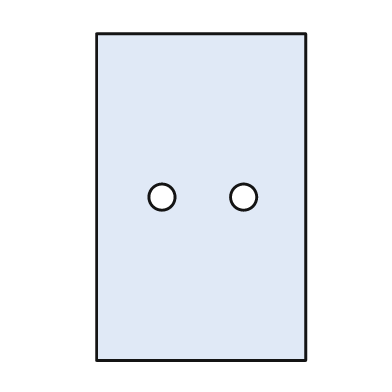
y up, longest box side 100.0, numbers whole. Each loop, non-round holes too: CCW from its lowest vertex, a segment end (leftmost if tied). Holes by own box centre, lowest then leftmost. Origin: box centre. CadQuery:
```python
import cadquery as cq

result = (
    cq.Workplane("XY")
    .moveTo(-32.0, -50.0)
    .lineTo(32.0, -50.0)
    .lineTo(32.0, 50.0)
    .lineTo(-32.0, 50.0)
    .close()
    .moveTo(-12.0, 0.0)
    .circle(4.0)
    .moveTo(13.0, 0.0)
    .circle(4.0)
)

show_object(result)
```